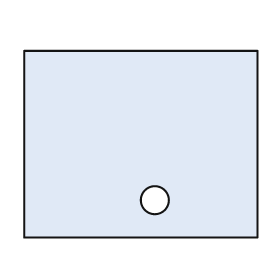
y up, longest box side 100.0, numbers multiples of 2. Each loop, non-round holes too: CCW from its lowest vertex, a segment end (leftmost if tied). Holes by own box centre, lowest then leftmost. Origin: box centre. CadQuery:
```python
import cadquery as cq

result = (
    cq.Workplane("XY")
    .moveTo(-50.0, -40.0)
    .lineTo(50.0, -40.0)
    .lineTo(50.0, 40.0)
    .lineTo(-50.0, 40.0)
    .close()
    .moveTo(6.0, -24.0)
    .circle(6.0)
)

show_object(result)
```